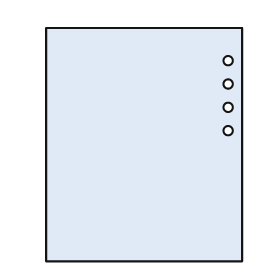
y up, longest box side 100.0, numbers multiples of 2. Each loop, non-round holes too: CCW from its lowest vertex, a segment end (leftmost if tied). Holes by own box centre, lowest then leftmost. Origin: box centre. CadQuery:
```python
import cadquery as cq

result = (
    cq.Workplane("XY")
    .moveTo(-42.0, -50.0)
    .lineTo(42.0, -50.0)
    .lineTo(42.0, 50.0)
    .lineTo(-42.0, 50.0)
    .close()
    .moveTo(36.0, 6.0)
    .circle(2.0)
    .moveTo(36.0, 16.0)
    .circle(2.0)
    .moveTo(36.0, 26.0)
    .circle(2.0)
    .moveTo(36.0, 36.0)
    .circle(2.0)
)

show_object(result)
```